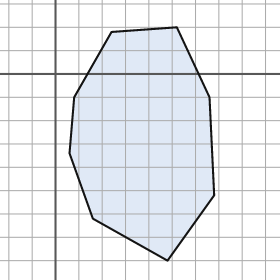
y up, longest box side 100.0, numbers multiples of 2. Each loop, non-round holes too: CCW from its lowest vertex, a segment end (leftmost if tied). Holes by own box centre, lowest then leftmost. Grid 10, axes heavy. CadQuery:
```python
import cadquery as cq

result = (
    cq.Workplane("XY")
    .moveTo(48.0, -80.0)
    .lineTo(68.0, -52.0)
    .lineTo(66.0, -10.0)
    .lineTo(52.0, 20.0)
    .lineTo(24.0, 18.0)
    .lineTo(8.0, -10.0)
    .lineTo(6.0, -34.0)
    .lineTo(16.0, -62.0)
    .close()
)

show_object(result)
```